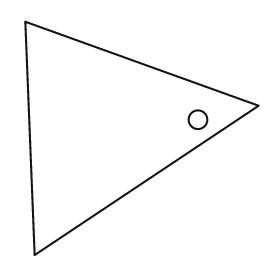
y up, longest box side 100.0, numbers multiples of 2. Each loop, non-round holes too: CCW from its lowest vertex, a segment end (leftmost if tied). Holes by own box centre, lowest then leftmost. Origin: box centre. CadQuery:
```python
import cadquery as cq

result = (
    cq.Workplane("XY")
    .moveTo(-46.0, -50.0)
    .lineTo(50.0, 14.0)
    .lineTo(-50.0, 50.0)
    .close()
    .moveTo(24.0, 8.0)
    .circle(4.0)
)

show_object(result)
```